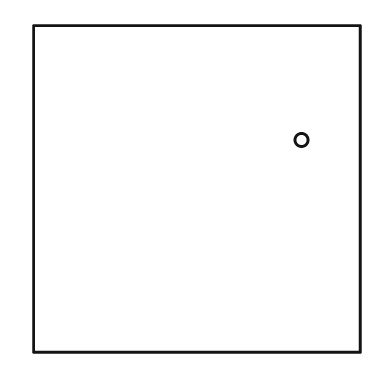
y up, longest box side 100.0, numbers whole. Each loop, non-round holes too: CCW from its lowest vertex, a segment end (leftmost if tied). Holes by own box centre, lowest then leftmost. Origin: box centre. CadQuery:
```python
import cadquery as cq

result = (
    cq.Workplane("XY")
    .moveTo(-50.0, -50.0)
    .lineTo(50.0, -50.0)
    .lineTo(50.0, 50.0)
    .lineTo(-50.0, 50.0)
    .close()
    .moveTo(32.0, 15.0)
    .circle(2.0)
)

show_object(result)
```